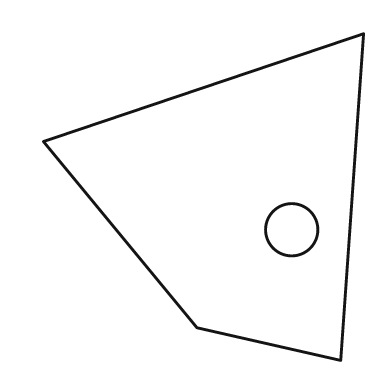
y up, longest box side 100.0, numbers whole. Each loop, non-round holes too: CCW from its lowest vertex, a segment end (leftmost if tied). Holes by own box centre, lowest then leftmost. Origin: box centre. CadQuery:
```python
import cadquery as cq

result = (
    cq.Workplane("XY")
    .moveTo(42.0, -50.0)
    .lineTo(49.0, 50.0)
    .lineTo(-49.0, 17.0)
    .lineTo(-2.0, -40.0)
    .close()
    .moveTo(27.0, -10.0)
    .circle(8.0)
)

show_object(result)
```